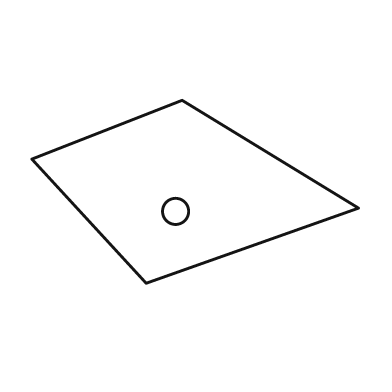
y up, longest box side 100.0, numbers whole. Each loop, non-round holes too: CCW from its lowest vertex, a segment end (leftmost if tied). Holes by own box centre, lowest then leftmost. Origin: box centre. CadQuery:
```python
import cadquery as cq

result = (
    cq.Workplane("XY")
    .moveTo(-15.0, -28.0)
    .lineTo(50.0, -5.0)
    .lineTo(-4.0, 28.0)
    .lineTo(-50.0, 10.0)
    .close()
    .moveTo(-6.0, -6.0)
    .circle(4.0)
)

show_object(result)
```